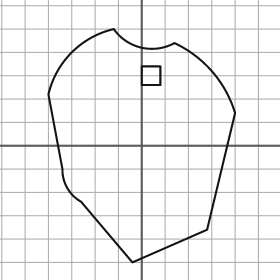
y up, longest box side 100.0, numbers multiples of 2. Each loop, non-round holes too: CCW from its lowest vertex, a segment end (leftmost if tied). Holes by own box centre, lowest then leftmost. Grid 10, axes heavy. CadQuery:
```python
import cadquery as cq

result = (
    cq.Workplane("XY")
    .moveTo(-4.0, -50.0)
    .lineTo(28.0, -36.0)
    .lineTo(40.0, 14.0)
    .threePointArc((30.0, 32.0), (14.0, 44.0))
    .threePointArc((0.0, 42.0), (-12.0, 50.0))
    .threePointArc((-30.0, 40.0), (-40.0, 22.0))
    .lineTo(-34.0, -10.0)
    .threePointArc((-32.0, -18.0), (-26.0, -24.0))
    .close()
    .moveTo(0.0, 26.0)
    .lineTo(8.0, 26.0)
    .lineTo(8.0, 34.0)
    .lineTo(0.0, 34.0)
    .close()
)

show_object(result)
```